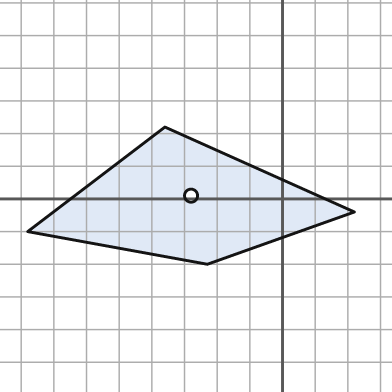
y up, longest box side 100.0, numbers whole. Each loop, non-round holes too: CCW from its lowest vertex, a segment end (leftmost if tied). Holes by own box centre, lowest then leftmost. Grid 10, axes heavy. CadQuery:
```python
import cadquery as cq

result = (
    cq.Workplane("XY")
    .moveTo(-23.0, -20.0)
    .lineTo(22.0, -4.0)
    .lineTo(-36.0, 22.0)
    .lineTo(-78.0, -10.0)
    .close()
    .moveTo(-28.0, 1.0)
    .circle(2.0)
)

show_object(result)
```